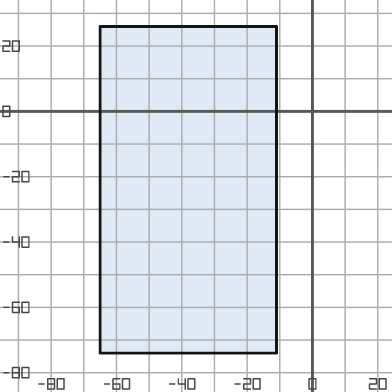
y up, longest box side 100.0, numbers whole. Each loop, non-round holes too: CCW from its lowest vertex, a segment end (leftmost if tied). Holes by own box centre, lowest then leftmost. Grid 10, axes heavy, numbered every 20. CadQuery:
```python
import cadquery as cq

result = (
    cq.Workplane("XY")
    .moveTo(-65.0, -74.0)
    .lineTo(-11.0, -74.0)
    .lineTo(-11.0, 26.0)
    .lineTo(-65.0, 26.0)
    .close()
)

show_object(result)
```